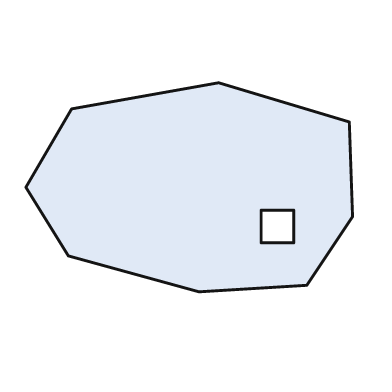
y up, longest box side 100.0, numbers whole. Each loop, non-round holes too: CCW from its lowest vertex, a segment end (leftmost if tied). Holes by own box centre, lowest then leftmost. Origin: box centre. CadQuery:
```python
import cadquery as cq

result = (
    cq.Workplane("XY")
    .moveTo(3.0, -32.0)
    .lineTo(36.0, -30.0)
    .lineTo(50.0, -9.0)
    .lineTo(49.0, 20.0)
    .lineTo(9.0, 32.0)
    .lineTo(-36.0, 24.0)
    .lineTo(-50.0, 0.0)
    .lineTo(-37.0, -21.0)
    .close()
    .moveTo(22.0, -17.0)
    .lineTo(32.0, -17.0)
    .lineTo(32.0, -7.0)
    .lineTo(22.0, -7.0)
    .close()
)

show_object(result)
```